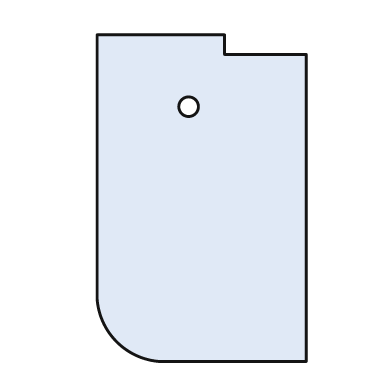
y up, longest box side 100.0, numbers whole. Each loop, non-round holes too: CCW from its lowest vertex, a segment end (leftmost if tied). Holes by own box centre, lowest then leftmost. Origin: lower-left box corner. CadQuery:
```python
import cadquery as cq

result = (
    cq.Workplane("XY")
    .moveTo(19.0, 0.0)
    .lineTo(64.0, 0.0)
    .lineTo(64.0, 94.0)
    .lineTo(39.0, 94.0)
    .lineTo(39.0, 100.0)
    .lineTo(0.0, 100.0)
    .lineTo(0.0, 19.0)
    .threePointArc((6.0, 6.0), (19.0, 0.0))
    .close()
    .moveTo(28.0, 78.0)
    .circle(3.0)
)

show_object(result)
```